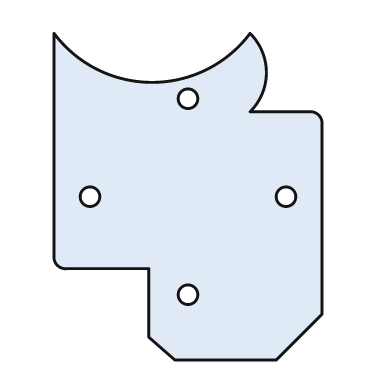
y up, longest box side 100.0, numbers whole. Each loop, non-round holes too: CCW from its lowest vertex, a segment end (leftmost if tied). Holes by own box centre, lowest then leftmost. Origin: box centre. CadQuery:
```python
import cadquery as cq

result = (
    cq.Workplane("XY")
    .moveTo(-4.0, -50.0)
    .lineTo(27.0, -50.0)
    .lineTo(41.0, -36.0)
    .lineTo(41.0, 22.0)
    .threePointArc((40.0, 25.0), (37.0, 26.0))
    .lineTo(19.0, 26.0)
    .threePointArc((24.0, 38.0), (19.0, 50.0))
    .threePointArc((-11.0, 35.0), (-41.0, 50.0))
    .lineTo(-41.0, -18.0)
    .threePointArc((-40.0, -21.0), (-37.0, -22.0))
    .lineTo(-12.0, -22.0)
    .lineTo(-12.0, -43.0)
    .close()
    .moveTo(0.0, -30.0)
    .circle(3.0)
    .moveTo(-30.0, 0.0)
    .circle(3.0)
    .moveTo(30.0, 0.0)
    .circle(3.0)
    .moveTo(0.0, 30.0)
    .circle(3.0)
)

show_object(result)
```